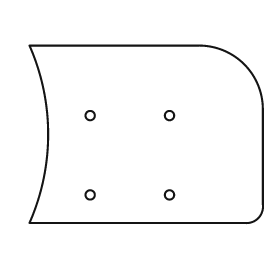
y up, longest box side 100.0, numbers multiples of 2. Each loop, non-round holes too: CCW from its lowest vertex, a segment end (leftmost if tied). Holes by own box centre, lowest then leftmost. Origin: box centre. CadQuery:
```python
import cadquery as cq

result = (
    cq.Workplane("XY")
    .moveTo(-50.0, -38.0)
    .lineTo(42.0, -38.0)
    .threePointArc((48.0, -36.0), (50.0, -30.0))
    .lineTo(50.0, 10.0)
    .threePointArc((42.0, 30.0), (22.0, 38.0))
    .lineTo(-50.0, 38.0)
    .threePointArc((-42.0, 0.0), (-50.0, -38.0))
    .close()
    .moveTo(-24.0, -26.0)
    .circle(2.0)
    .moveTo(10.0, -26.0)
    .circle(2.0)
    .moveTo(-24.0, 8.0)
    .circle(2.0)
    .moveTo(10.0, 8.0)
    .circle(2.0)
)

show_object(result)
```